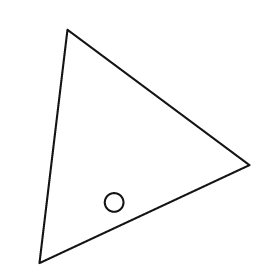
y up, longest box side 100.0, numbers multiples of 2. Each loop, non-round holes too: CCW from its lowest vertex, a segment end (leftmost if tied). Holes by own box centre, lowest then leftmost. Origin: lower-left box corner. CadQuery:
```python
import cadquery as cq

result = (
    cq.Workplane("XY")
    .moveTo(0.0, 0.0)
    .lineTo(90.0, 42.0)
    .lineTo(12.0, 100.0)
    .close()
    .moveTo(32.0, 26.0)
    .circle(4.0)
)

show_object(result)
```